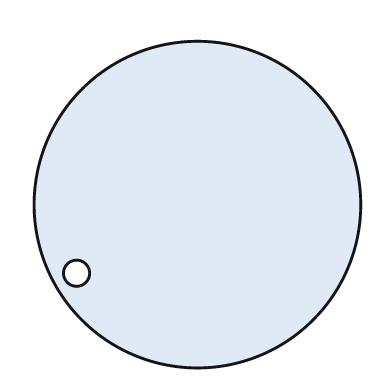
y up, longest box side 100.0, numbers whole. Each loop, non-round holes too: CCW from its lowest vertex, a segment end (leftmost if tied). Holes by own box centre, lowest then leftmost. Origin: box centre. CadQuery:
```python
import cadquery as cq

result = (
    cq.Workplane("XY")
    .moveTo(0.0, 0.0)
    .circle(50.0)
    .moveTo(-37.0, -21.0)
    .circle(4.0)
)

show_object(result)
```